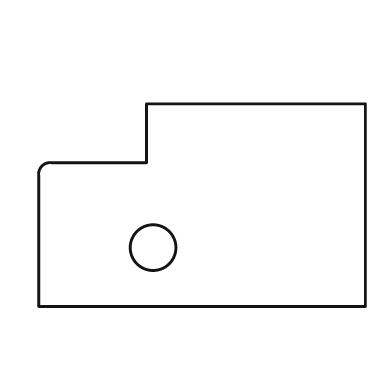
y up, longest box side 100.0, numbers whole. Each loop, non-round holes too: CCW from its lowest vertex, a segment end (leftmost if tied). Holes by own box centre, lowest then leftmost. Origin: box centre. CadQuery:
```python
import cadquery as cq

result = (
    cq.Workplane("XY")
    .moveTo(-50.0, -31.0)
    .lineTo(50.0, -31.0)
    .lineTo(50.0, 31.0)
    .lineTo(-17.0, 31.0)
    .lineTo(-17.0, 13.0)
    .lineTo(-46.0, 13.0)
    .threePointArc((-49.0, 12.0), (-50.0, 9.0))
    .close()
    .moveTo(-15.0, -13.0)
    .circle(7.0)
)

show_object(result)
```